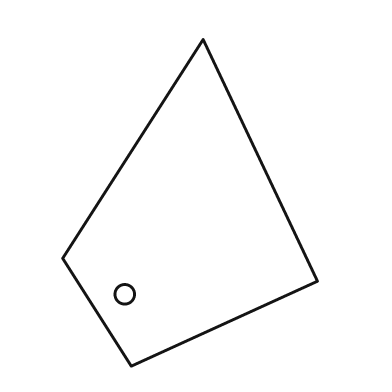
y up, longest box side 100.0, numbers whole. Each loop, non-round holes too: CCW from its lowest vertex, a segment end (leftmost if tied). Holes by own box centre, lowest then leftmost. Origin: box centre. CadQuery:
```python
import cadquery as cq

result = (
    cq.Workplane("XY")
    .moveTo(-18.0, -50.0)
    .lineTo(39.0, -24.0)
    .lineTo(4.0, 50.0)
    .lineTo(-39.0, -17.0)
    .close()
    .moveTo(-20.0, -28.0)
    .circle(3.0)
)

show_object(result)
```